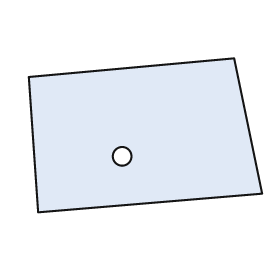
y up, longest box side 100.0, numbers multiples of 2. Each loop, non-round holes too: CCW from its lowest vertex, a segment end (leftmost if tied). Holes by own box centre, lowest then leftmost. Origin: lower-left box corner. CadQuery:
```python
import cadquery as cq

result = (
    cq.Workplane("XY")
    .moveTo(4.0, 0.0)
    .lineTo(100.0, 8.0)
    .lineTo(88.0, 66.0)
    .lineTo(0.0, 58.0)
    .close()
    .moveTo(40.0, 24.0)
    .circle(4.0)
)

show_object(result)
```